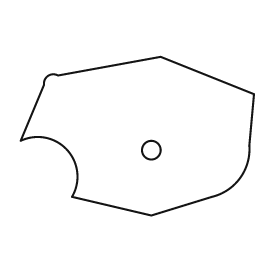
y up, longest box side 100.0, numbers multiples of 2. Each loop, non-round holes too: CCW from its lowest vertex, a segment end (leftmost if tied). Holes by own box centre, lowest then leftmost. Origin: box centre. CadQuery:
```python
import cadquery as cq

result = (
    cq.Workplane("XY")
    .moveTo(6.0, -34.0)
    .lineTo(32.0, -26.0)
    .threePointArc((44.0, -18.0), (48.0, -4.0))
    .lineTo(50.0, 18.0)
    .lineTo(10.0, 34.0)
    .lineTo(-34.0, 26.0)
    .threePointArc((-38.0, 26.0), (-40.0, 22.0))
    .lineTo(-50.0, -2.0)
    .threePointArc((-30.0, -6.0), (-28.0, -26.0))
    .close()
    .moveTo(6.0, -6.0)
    .circle(4.0)
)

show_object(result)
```